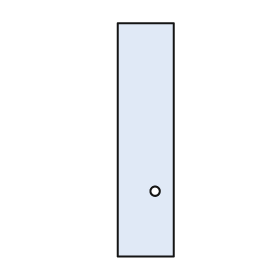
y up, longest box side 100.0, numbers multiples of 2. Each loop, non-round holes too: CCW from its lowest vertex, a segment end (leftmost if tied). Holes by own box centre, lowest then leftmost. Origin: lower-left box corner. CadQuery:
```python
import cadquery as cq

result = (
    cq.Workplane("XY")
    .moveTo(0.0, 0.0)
    .lineTo(24.0, 0.0)
    .lineTo(24.0, 100.0)
    .lineTo(0.0, 100.0)
    .close()
    .moveTo(16.0, 28.0)
    .circle(2.0)
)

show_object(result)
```